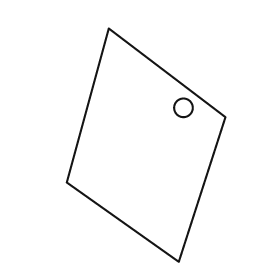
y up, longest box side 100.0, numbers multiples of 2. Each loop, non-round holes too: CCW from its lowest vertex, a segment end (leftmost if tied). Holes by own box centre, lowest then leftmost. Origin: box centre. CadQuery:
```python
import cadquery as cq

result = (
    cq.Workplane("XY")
    .moveTo(14.0, -50.0)
    .lineTo(34.0, 12.0)
    .lineTo(-16.0, 50.0)
    .lineTo(-34.0, -16.0)
    .close()
    .moveTo(16.0, 16.0)
    .circle(4.0)
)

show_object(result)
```